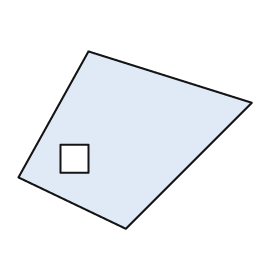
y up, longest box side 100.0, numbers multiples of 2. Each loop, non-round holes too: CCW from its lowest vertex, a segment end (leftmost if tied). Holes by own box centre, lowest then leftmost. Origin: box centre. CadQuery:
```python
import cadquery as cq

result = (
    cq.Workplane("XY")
    .moveTo(-4.0, -38.0)
    .lineTo(50.0, 16.0)
    .lineTo(-20.0, 38.0)
    .lineTo(-50.0, -16.0)
    .close()
    .moveTo(-32.0, -14.0)
    .lineTo(-20.0, -14.0)
    .lineTo(-20.0, -2.0)
    .lineTo(-32.0, -2.0)
    .close()
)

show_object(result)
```